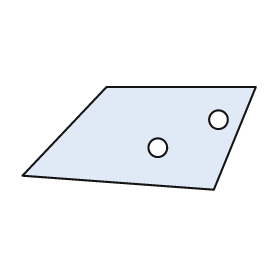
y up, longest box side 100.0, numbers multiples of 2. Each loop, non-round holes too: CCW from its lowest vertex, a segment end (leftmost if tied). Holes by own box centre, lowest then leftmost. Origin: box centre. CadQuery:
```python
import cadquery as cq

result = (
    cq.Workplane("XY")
    .moveTo(32.0, -22.0)
    .lineTo(50.0, 22.0)
    .lineTo(-14.0, 22.0)
    .lineTo(-50.0, -16.0)
    .close()
    .moveTo(8.0, -4.0)
    .circle(4.0)
    .moveTo(34.0, 8.0)
    .circle(4.0)
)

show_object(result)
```